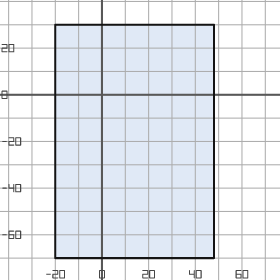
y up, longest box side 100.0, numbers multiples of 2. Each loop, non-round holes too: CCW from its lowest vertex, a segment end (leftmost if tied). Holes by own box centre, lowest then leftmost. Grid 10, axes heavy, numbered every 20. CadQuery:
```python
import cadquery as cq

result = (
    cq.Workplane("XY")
    .moveTo(-20.0, -70.0)
    .lineTo(48.0, -70.0)
    .lineTo(48.0, 30.0)
    .lineTo(-20.0, 30.0)
    .close()
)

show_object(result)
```